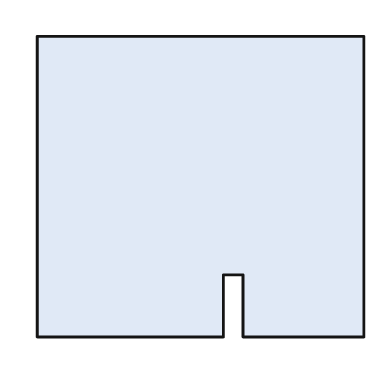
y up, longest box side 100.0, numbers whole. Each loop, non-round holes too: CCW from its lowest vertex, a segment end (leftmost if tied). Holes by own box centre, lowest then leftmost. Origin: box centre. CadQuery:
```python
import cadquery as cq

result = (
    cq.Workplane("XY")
    .moveTo(-50.0, -46.0)
    .lineTo(7.0, -46.0)
    .lineTo(7.0, -27.0)
    .lineTo(13.0, -27.0)
    .lineTo(13.0, -46.0)
    .lineTo(50.0, -46.0)
    .lineTo(50.0, 46.0)
    .lineTo(-50.0, 46.0)
    .close()
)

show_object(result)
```